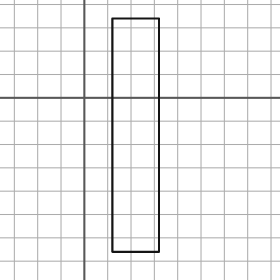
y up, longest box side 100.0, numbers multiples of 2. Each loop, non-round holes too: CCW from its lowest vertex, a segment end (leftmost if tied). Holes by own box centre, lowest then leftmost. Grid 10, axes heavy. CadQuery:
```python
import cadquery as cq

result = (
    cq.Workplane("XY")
    .moveTo(12.0, -66.0)
    .lineTo(32.0, -66.0)
    .lineTo(32.0, 34.0)
    .lineTo(12.0, 34.0)
    .close()
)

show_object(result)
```